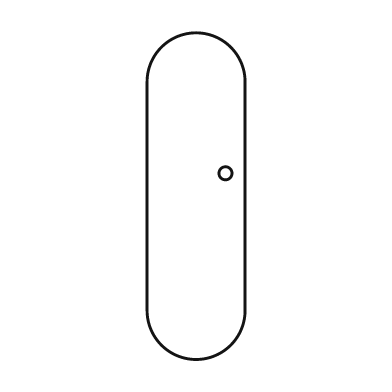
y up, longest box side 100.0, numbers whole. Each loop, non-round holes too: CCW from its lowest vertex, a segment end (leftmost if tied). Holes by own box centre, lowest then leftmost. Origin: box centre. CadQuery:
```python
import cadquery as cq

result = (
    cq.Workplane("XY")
    .moveTo(-15.0, -35.0)
    .threePointArc((0.0, -50.0), (15.0, -35.0))
    .lineTo(15.0, 35.0)
    .threePointArc((0.0, 50.0), (-15.0, 35.0))
    .close()
    .moveTo(9.0, 7.0)
    .circle(2.0)
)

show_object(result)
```